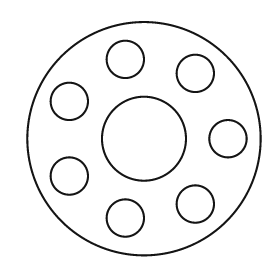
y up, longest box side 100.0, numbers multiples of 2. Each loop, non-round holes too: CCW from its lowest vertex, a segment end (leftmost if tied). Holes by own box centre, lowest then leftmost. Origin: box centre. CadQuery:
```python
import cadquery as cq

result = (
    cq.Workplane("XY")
    .moveTo(0.0, 0.0)
    .circle(50.0)
    .moveTo(-8.0, -34.0)
    .circle(8.0)
    .moveTo(22.0, -28.0)
    .circle(8.0)
    .moveTo(-32.0, -16.0)
    .circle(8.0)
    .moveTo(0.0, 0.0)
    .circle(18.0)
    .moveTo(36.0, 0.0)
    .circle(8.0)
    .moveTo(-32.0, 16.0)
    .circle(8.0)
    .moveTo(22.0, 28.0)
    .circle(8.0)
    .moveTo(-8.0, 34.0)
    .circle(8.0)
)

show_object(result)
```